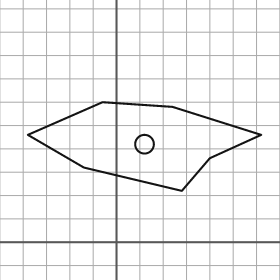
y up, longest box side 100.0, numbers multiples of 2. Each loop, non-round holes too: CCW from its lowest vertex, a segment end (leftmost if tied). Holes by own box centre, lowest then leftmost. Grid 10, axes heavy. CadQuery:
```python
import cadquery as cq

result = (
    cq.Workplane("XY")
    .moveTo(28.0, 22.0)
    .lineTo(40.0, 36.0)
    .lineTo(62.0, 46.0)
    .lineTo(24.0, 58.0)
    .lineTo(-6.0, 60.0)
    .lineTo(-38.0, 46.0)
    .lineTo(-14.0, 32.0)
    .close()
    .moveTo(12.0, 42.0)
    .circle(4.0)
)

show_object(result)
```